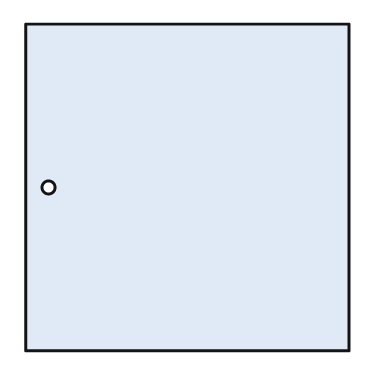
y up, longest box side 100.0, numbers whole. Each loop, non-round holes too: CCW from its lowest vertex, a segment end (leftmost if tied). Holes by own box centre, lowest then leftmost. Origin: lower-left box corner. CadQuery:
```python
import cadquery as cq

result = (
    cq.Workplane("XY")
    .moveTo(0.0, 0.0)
    .lineTo(99.0, 0.0)
    .lineTo(99.0, 100.0)
    .lineTo(0.0, 100.0)
    .close()
    .moveTo(7.0, 50.0)
    .circle(2.0)
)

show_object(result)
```